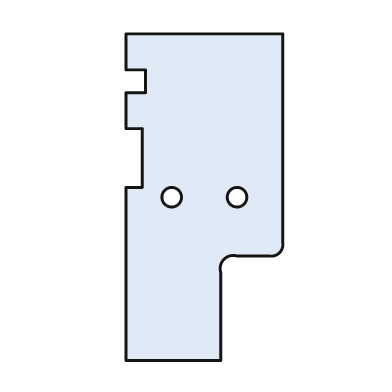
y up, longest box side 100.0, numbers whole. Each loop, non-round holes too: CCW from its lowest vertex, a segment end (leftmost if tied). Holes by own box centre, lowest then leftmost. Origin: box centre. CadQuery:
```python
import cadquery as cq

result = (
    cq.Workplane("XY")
    .moveTo(-24.0, -50.0)
    .lineTo(5.0, -50.0)
    .lineTo(5.0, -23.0)
    .threePointArc((6.0, -19.0), (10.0, -18.0))
    .lineTo(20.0, -18.0)
    .threePointArc((23.0, -17.0), (24.0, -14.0))
    .lineTo(24.0, 50.0)
    .lineTo(-24.0, 50.0)
    .lineTo(-24.0, 39.0)
    .lineTo(-18.0, 39.0)
    .lineTo(-18.0, 32.0)
    .lineTo(-24.0, 32.0)
    .lineTo(-24.0, 21.0)
    .lineTo(-19.0, 21.0)
    .lineTo(-19.0, 3.0)
    .lineTo(-24.0, 3.0)
    .close()
    .moveTo(-10.0, 0.0)
    .circle(3.0)
    .moveTo(10.0, 0.0)
    .circle(3.0)
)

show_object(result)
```